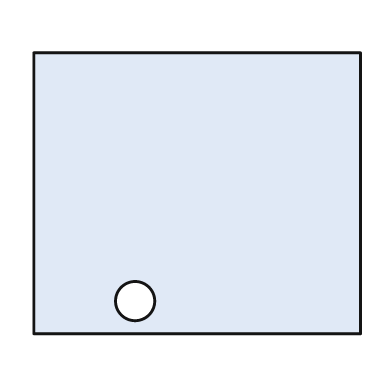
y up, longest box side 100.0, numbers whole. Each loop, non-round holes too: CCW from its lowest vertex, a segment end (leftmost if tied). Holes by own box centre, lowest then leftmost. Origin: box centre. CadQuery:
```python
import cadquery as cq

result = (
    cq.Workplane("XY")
    .moveTo(-50.0, -43.0)
    .lineTo(50.0, -43.0)
    .lineTo(50.0, 43.0)
    .lineTo(-50.0, 43.0)
    .close()
    .moveTo(-19.0, -33.0)
    .circle(6.0)
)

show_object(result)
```